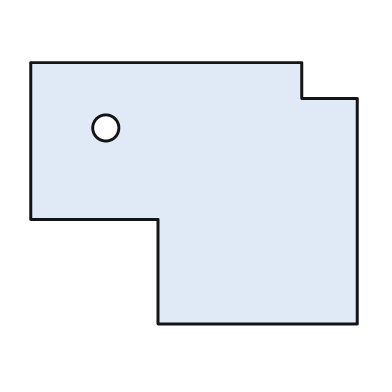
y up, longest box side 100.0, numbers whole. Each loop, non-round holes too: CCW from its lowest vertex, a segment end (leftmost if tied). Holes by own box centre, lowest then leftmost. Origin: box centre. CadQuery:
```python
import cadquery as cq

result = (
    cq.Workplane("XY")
    .moveTo(-11.0, -40.0)
    .lineTo(50.0, -40.0)
    .lineTo(50.0, 29.0)
    .lineTo(33.0, 29.0)
    .lineTo(33.0, 40.0)
    .lineTo(-50.0, 40.0)
    .lineTo(-50.0, -8.0)
    .lineTo(-11.0, -8.0)
    .close()
    .moveTo(-27.0, 20.0)
    .circle(4.0)
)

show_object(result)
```